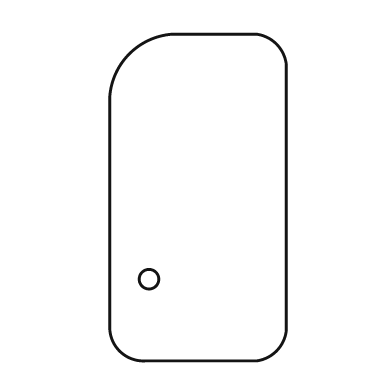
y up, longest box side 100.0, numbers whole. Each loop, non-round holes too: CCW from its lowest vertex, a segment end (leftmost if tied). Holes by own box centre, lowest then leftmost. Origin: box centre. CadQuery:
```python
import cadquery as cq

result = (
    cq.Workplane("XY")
    .moveTo(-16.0, -50.0)
    .lineTo(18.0, -50.0)
    .threePointArc((24.0, -47.0), (27.0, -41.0))
    .lineTo(27.0, 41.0)
    .threePointArc((24.0, 47.0), (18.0, 50.0))
    .lineTo(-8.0, 50.0)
    .threePointArc((-21.0, 44.0), (-27.0, 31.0))
    .lineTo(-27.0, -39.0)
    .threePointArc((-24.0, -47.0), (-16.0, -50.0))
    .close()
    .moveTo(-15.0, -25.0)
    .circle(3.0)
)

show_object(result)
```